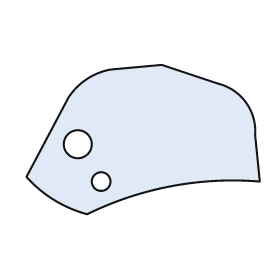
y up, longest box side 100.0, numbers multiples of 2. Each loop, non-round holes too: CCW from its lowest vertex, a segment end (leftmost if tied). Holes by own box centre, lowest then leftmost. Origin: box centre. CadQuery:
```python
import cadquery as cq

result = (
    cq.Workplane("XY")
    .moveTo(-24.0, -32.0)
    .threePointArc((12.0, -20.0), (50.0, -18.0))
    .lineTo(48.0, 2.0)
    .threePointArc((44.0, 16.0), (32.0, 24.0))
    .lineTo(8.0, 32.0)
    .lineTo(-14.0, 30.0)
    .threePointArc((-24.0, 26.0), (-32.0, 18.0))
    .lineTo(-50.0, -16.0)
    .threePointArc((-38.0, -26.0), (-24.0, -32.0))
    .close()
    .moveTo(-18.0, -18.0)
    .circle(4.0)
    .moveTo(-28.0, -2.0)
    .circle(6.0)
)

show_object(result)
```